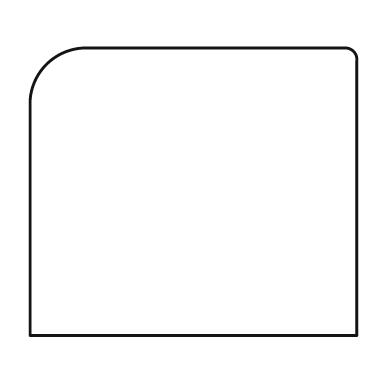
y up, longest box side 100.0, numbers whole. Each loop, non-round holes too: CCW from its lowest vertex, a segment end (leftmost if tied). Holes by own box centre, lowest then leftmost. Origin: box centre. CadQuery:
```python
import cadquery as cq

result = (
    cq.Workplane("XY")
    .moveTo(-50.0, -44.0)
    .lineTo(50.0, -44.0)
    .lineTo(50.0, 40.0)
    .threePointArc((49.0, 43.0), (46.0, 44.0))
    .lineTo(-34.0, 44.0)
    .threePointArc((-45.0, 39.0), (-50.0, 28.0))
    .close()
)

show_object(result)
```